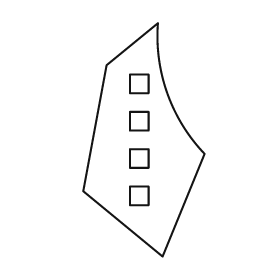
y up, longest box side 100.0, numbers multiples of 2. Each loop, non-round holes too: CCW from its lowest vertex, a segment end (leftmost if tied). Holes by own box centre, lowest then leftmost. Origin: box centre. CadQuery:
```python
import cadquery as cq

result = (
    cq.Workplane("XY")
    .moveTo(8.0, -50.0)
    .lineTo(26.0, -6.0)
    .threePointArc((10.0, 20.0), (6.0, 50.0))
    .lineTo(-16.0, 32.0)
    .lineTo(-26.0, -22.0)
    .close()
    .moveTo(-6.0, -28.0)
    .lineTo(2.0, -28.0)
    .lineTo(2.0, -20.0)
    .lineTo(-6.0, -20.0)
    .close()
    .moveTo(-6.0, -12.0)
    .lineTo(2.0, -12.0)
    .lineTo(2.0, -4.0)
    .lineTo(-6.0, -4.0)
    .close()
    .moveTo(-6.0, 4.0)
    .lineTo(2.0, 4.0)
    .lineTo(2.0, 12.0)
    .lineTo(-6.0, 12.0)
    .close()
    .moveTo(-6.0, 20.0)
    .lineTo(2.0, 20.0)
    .lineTo(2.0, 28.0)
    .lineTo(-6.0, 28.0)
    .close()
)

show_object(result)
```